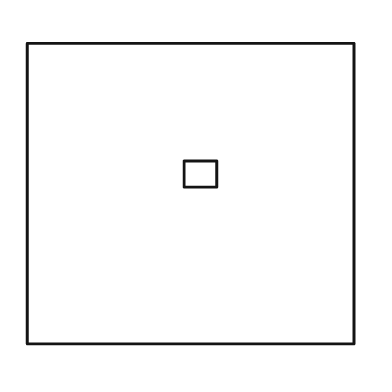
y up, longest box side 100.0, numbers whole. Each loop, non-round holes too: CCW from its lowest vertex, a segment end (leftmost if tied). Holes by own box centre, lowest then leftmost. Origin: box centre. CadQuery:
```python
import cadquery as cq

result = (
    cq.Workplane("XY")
    .moveTo(-50.0, -46.0)
    .lineTo(50.0, -46.0)
    .lineTo(50.0, 46.0)
    .lineTo(-50.0, 46.0)
    .close()
    .moveTo(-2.0, 2.0)
    .lineTo(8.0, 2.0)
    .lineTo(8.0, 10.0)
    .lineTo(-2.0, 10.0)
    .close()
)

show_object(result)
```